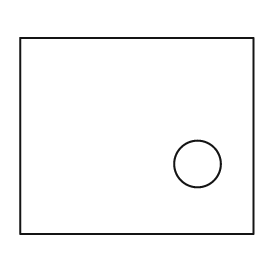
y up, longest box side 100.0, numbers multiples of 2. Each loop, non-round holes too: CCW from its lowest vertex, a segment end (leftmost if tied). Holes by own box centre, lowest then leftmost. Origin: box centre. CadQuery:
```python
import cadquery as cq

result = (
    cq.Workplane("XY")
    .moveTo(-50.0, -42.0)
    .lineTo(50.0, -42.0)
    .lineTo(50.0, 42.0)
    .lineTo(-50.0, 42.0)
    .close()
    .moveTo(26.0, -12.0)
    .circle(10.0)
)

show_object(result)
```